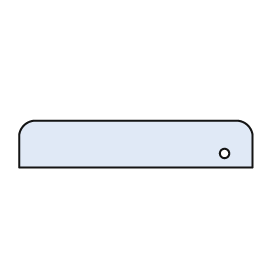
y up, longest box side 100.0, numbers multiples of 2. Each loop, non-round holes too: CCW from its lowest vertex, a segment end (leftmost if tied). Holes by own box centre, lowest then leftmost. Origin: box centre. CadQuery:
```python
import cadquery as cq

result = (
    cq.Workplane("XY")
    .moveTo(-50.0, -10.0)
    .lineTo(50.0, -10.0)
    .lineTo(50.0, 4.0)
    .threePointArc((48.0, 8.0), (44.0, 10.0))
    .lineTo(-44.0, 10.0)
    .threePointArc((-48.0, 8.0), (-50.0, 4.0))
    .close()
    .moveTo(38.0, -4.0)
    .circle(2.0)
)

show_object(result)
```